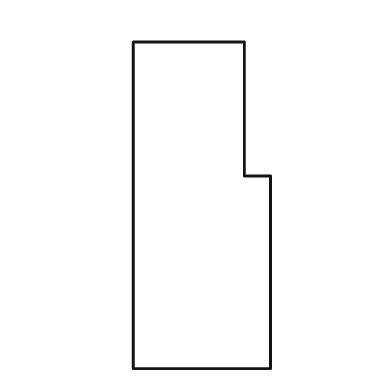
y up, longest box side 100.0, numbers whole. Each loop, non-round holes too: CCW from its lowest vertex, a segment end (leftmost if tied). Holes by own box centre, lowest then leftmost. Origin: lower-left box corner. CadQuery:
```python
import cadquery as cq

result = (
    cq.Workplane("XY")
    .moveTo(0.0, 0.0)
    .lineTo(42.0, 0.0)
    .lineTo(42.0, 59.0)
    .lineTo(34.0, 59.0)
    .lineTo(34.0, 100.0)
    .lineTo(0.0, 100.0)
    .close()
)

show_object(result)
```